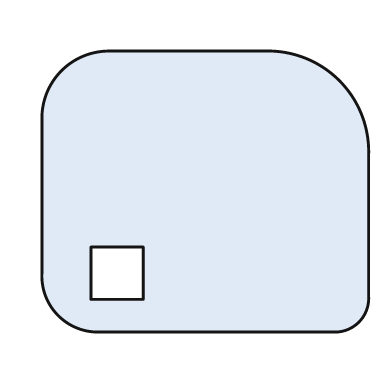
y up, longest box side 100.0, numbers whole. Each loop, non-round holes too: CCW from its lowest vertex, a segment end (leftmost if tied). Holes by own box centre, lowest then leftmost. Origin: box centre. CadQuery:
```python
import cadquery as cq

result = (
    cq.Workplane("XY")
    .moveTo(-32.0, -43.0)
    .lineTo(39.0, -43.0)
    .threePointArc((47.0, -40.0), (50.0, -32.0))
    .lineTo(50.0, 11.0)
    .threePointArc((41.0, 34.0), (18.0, 43.0))
    .lineTo(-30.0, 43.0)
    .threePointArc((-44.0, 37.0), (-50.0, 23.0))
    .lineTo(-50.0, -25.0)
    .threePointArc((-45.0, -38.0), (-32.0, -43.0))
    .close()
    .moveTo(-35.0, -33.0)
    .lineTo(-19.0, -33.0)
    .lineTo(-19.0, -17.0)
    .lineTo(-35.0, -17.0)
    .close()
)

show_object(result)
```